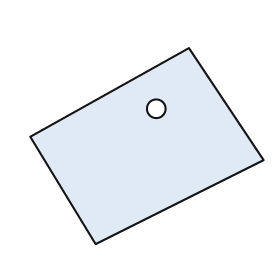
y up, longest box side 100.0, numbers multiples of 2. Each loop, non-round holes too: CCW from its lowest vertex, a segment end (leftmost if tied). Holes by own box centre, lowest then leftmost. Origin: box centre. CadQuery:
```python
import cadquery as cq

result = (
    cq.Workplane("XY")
    .moveTo(-22.0, -42.0)
    .lineTo(50.0, -6.0)
    .lineTo(18.0, 42.0)
    .lineTo(-50.0, 4.0)
    .close()
    .moveTo(4.0, 16.0)
    .circle(4.0)
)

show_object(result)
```